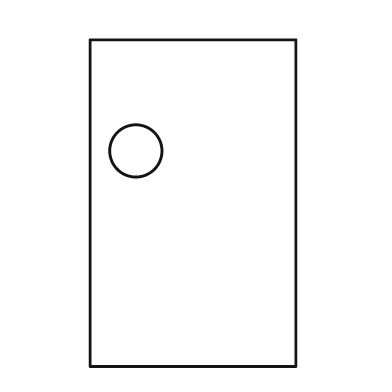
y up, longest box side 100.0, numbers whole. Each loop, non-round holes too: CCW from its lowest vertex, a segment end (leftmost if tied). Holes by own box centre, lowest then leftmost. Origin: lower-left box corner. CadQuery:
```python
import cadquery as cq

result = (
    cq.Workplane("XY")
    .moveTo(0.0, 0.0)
    .lineTo(63.0, 0.0)
    .lineTo(63.0, 100.0)
    .lineTo(0.0, 100.0)
    .close()
    .moveTo(14.0, 66.0)
    .circle(8.0)
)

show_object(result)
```